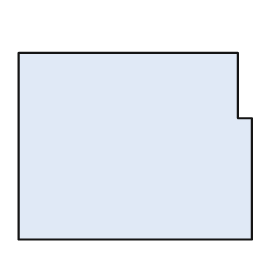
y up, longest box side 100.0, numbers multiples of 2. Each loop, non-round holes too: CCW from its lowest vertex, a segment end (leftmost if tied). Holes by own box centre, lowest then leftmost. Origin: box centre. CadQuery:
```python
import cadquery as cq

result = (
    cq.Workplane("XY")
    .moveTo(-50.0, -40.0)
    .lineTo(50.0, -40.0)
    .lineTo(50.0, 12.0)
    .lineTo(44.0, 12.0)
    .lineTo(44.0, 40.0)
    .lineTo(-50.0, 40.0)
    .close()
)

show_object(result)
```